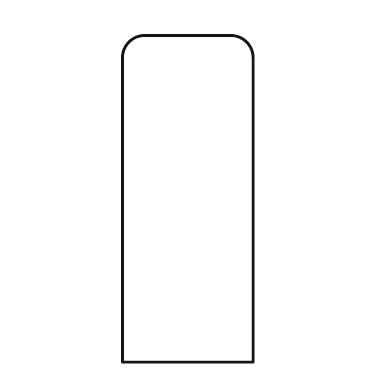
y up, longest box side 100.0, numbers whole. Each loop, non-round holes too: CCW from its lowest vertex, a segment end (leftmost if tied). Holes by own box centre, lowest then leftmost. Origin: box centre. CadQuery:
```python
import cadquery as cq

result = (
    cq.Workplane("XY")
    .moveTo(-20.0, -50.0)
    .lineTo(20.0, -50.0)
    .lineTo(20.0, 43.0)
    .threePointArc((18.0, 48.0), (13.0, 50.0))
    .lineTo(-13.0, 50.0)
    .threePointArc((-18.0, 48.0), (-20.0, 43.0))
    .close()
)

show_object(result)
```